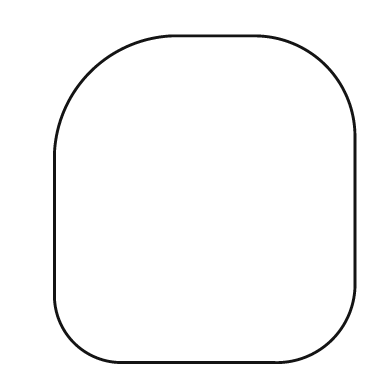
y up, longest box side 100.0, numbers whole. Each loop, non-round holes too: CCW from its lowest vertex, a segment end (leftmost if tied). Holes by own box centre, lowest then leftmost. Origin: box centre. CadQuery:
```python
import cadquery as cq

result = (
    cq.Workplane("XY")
    .moveTo(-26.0, -50.0)
    .lineTo(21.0, -50.0)
    .threePointArc((39.0, -43.0), (46.0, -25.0))
    .lineTo(46.0, 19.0)
    .threePointArc((37.0, 41.0), (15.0, 50.0))
    .lineTo(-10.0, 50.0)
    .threePointArc((-35.0, 39.0), (-46.0, 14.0))
    .lineTo(-46.0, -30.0)
    .threePointArc((-40.0, -44.0), (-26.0, -50.0))
    .close()
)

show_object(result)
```